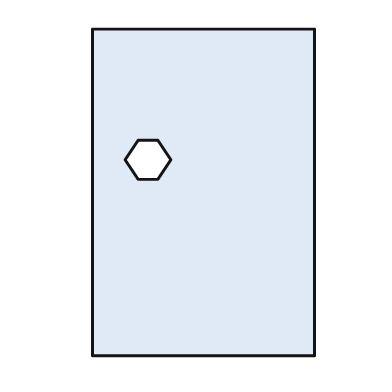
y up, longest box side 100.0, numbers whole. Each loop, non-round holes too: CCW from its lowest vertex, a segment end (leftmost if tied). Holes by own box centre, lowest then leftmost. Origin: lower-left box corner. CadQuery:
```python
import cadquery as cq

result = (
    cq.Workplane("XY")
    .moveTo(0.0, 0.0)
    .lineTo(68.0, 0.0)
    .lineTo(68.0, 100.0)
    .lineTo(0.0, 100.0)
    .close()
    .moveTo(14.0, 54.0)
    .lineTo(20.0, 54.0)
    .lineTo(24.0, 60.0)
    .lineTo(20.0, 66.0)
    .lineTo(14.0, 66.0)
    .lineTo(10.0, 60.0)
    .close()
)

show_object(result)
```